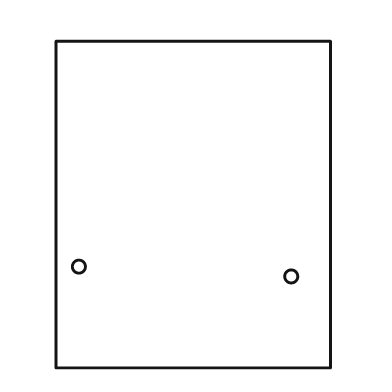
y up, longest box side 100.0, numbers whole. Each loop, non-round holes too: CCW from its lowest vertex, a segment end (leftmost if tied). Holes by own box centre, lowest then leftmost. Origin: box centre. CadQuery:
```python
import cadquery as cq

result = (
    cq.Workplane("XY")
    .moveTo(-42.0, -50.0)
    .lineTo(42.0, -50.0)
    .lineTo(42.0, 50.0)
    .lineTo(-42.0, 50.0)
    .close()
    .moveTo(30.0, -22.0)
    .circle(2.0)
    .moveTo(-35.0, -19.0)
    .circle(2.0)
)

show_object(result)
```